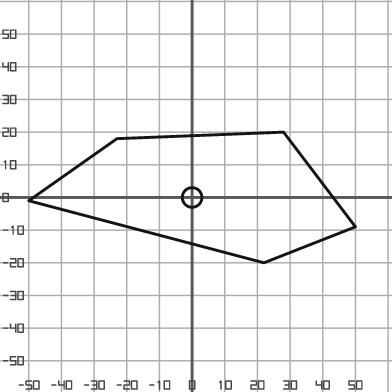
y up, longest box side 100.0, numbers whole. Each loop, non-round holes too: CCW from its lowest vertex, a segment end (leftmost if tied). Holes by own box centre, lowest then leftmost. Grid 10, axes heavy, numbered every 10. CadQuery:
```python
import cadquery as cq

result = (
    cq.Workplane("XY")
    .moveTo(22.0, -20.0)
    .lineTo(50.0, -9.0)
    .lineTo(28.0, 20.0)
    .lineTo(-23.0, 18.0)
    .lineTo(-50.0, -1.0)
    .close()
    .moveTo(0.0, 0.0)
    .circle(3.0)
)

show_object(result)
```